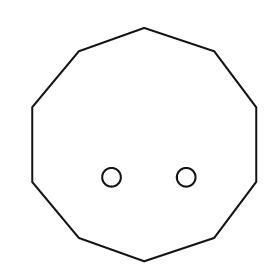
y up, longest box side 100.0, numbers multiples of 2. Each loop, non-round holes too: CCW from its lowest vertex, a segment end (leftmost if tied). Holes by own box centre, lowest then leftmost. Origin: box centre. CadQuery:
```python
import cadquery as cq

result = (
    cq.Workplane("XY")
    .moveTo(0.0, -50.0)
    .lineTo(30.0, -40.0)
    .lineTo(48.0, -16.0)
    .lineTo(48.0, 16.0)
    .lineTo(30.0, 40.0)
    .lineTo(0.0, 50.0)
    .lineTo(-28.0, 40.0)
    .lineTo(-48.0, 16.0)
    .lineTo(-48.0, -16.0)
    .lineTo(-28.0, -40.0)
    .close()
    .moveTo(-14.0, -14.0)
    .circle(4.0)
    .moveTo(18.0, -14.0)
    .circle(4.0)
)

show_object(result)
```